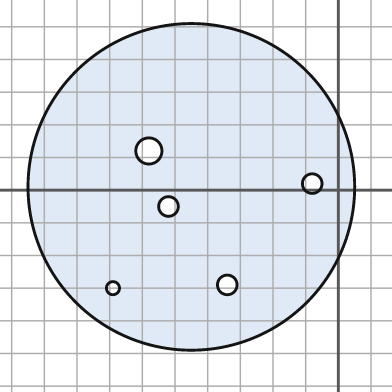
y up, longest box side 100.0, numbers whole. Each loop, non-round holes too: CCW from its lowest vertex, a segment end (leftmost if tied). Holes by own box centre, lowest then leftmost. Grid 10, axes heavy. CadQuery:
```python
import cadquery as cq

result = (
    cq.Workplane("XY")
    .moveTo(-45.0, 1.0)
    .circle(50.0)
    .moveTo(-69.0, -30.0)
    .circle(2.0)
    .moveTo(-34.0, -29.0)
    .circle(3.0)
    .moveTo(-52.0, -5.0)
    .circle(3.0)
    .moveTo(-8.0, 2.0)
    .circle(3.0)
    .moveTo(-58.0, 12.0)
    .circle(4.0)
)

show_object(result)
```